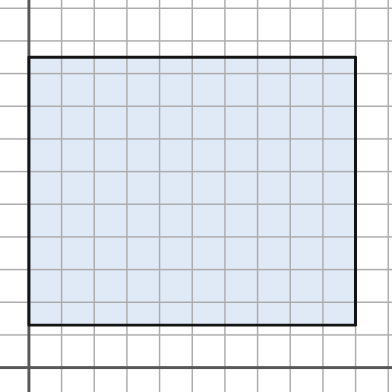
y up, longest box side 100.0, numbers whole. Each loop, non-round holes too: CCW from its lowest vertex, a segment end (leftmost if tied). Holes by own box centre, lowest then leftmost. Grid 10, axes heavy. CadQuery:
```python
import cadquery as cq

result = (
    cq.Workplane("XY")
    .moveTo(0.0, 13.0)
    .lineTo(100.0, 13.0)
    .lineTo(100.0, 95.0)
    .lineTo(0.0, 95.0)
    .close()
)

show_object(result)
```